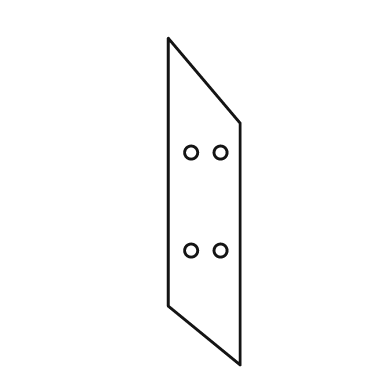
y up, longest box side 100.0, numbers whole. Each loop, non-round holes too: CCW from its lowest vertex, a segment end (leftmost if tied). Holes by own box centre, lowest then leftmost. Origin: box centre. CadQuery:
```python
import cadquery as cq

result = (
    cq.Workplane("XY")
    .moveTo(11.0, -50.0)
    .lineTo(11.0, 24.0)
    .lineTo(-11.0, 50.0)
    .lineTo(-11.0, -32.0)
    .close()
    .moveTo(-4.0, -15.0)
    .circle(2.0)
    .moveTo(5.0, -15.0)
    .circle(2.0)
    .moveTo(-4.0, 15.0)
    .circle(2.0)
    .moveTo(5.0, 15.0)
    .circle(2.0)
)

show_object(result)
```